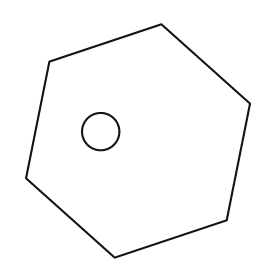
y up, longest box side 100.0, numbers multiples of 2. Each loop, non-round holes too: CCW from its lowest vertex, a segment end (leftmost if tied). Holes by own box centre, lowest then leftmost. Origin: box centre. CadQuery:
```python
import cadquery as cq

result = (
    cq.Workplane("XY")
    .moveTo(-10.0, -50.0)
    .lineTo(38.0, -34.0)
    .lineTo(48.0, 16.0)
    .lineTo(10.0, 50.0)
    .lineTo(-38.0, 34.0)
    .lineTo(-48.0, -16.0)
    .close()
    .moveTo(-16.0, 4.0)
    .circle(8.0)
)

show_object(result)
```